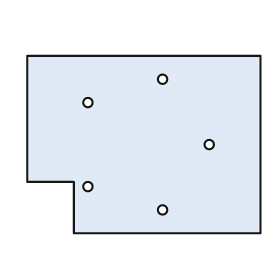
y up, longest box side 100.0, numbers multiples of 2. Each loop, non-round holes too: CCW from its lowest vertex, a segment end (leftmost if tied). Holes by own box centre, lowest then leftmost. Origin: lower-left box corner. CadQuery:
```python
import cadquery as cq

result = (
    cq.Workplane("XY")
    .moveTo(20.0, 0.0)
    .lineTo(100.0, 0.0)
    .lineTo(100.0, 76.0)
    .lineTo(0.0, 76.0)
    .lineTo(0.0, 22.0)
    .lineTo(20.0, 22.0)
    .close()
    .moveTo(58.0, 10.0)
    .circle(2.0)
    .moveTo(26.0, 20.0)
    .circle(2.0)
    .moveTo(78.0, 38.0)
    .circle(2.0)
    .moveTo(26.0, 56.0)
    .circle(2.0)
    .moveTo(58.0, 66.0)
    .circle(2.0)
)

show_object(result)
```